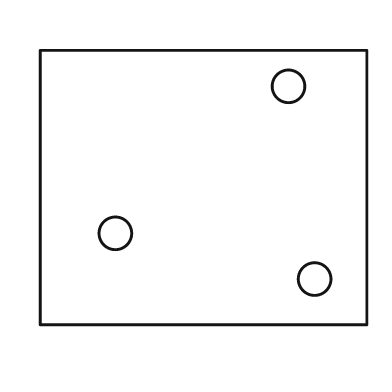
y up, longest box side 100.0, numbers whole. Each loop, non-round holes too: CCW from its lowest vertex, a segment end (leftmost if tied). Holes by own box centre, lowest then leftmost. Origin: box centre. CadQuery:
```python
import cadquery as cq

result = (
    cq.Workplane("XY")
    .moveTo(-50.0, -42.0)
    .lineTo(50.0, -42.0)
    .lineTo(50.0, 42.0)
    .lineTo(-50.0, 42.0)
    .close()
    .moveTo(34.0, -28.0)
    .circle(5.0)
    .moveTo(-27.0, -14.0)
    .circle(5.0)
    .moveTo(26.0, 31.0)
    .circle(5.0)
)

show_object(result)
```